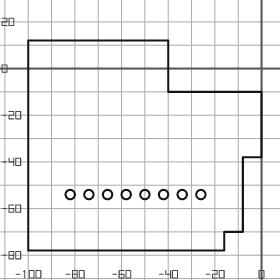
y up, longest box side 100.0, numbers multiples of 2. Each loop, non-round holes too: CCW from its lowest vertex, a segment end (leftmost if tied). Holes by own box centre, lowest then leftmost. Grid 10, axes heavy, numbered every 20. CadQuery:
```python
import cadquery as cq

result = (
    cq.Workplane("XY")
    .moveTo(-100.0, -78.0)
    .lineTo(-16.0, -78.0)
    .lineTo(-16.0, -70.0)
    .lineTo(-8.0, -70.0)
    .lineTo(-8.0, -38.0)
    .lineTo(0.0, -38.0)
    .lineTo(0.0, -10.0)
    .lineTo(-40.0, -10.0)
    .lineTo(-40.0, 12.0)
    .lineTo(-100.0, 12.0)
    .close()
    .moveTo(-82.0, -54.0)
    .circle(2.0)
    .moveTo(-74.0, -54.0)
    .circle(2.0)
    .moveTo(-66.0, -54.0)
    .circle(2.0)
    .moveTo(-58.0, -54.0)
    .circle(2.0)
    .moveTo(-50.0, -54.0)
    .circle(2.0)
    .moveTo(-42.0, -54.0)
    .circle(2.0)
    .moveTo(-34.0, -54.0)
    .circle(2.0)
    .moveTo(-26.0, -54.0)
    .circle(2.0)
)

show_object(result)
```